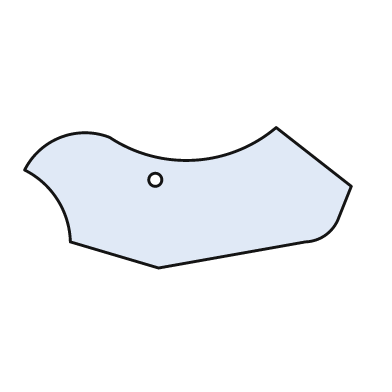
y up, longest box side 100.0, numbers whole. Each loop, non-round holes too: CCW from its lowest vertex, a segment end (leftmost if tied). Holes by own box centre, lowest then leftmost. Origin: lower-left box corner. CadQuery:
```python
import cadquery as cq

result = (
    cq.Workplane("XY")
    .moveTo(41.0, 0.0)
    .lineTo(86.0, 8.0)
    .threePointArc((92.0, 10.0), (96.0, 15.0))
    .lineTo(100.0, 25.0)
    .lineTo(77.0, 43.0)
    .threePointArc((52.0, 33.0), (26.0, 40.0))
    .threePointArc((11.0, 40.0), (0.0, 30.0))
    .threePointArc((10.0, 21.0), (14.0, 8.0))
    .close()
    .moveTo(40.0, 27.0)
    .circle(2.0)
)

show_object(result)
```